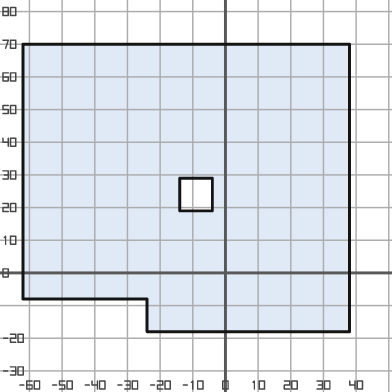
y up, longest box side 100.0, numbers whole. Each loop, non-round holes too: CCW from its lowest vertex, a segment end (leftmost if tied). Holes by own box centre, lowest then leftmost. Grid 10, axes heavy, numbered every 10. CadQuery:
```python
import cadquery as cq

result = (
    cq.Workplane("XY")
    .moveTo(-24.0, -18.0)
    .lineTo(38.0, -18.0)
    .lineTo(38.0, 70.0)
    .lineTo(-62.0, 70.0)
    .lineTo(-62.0, -8.0)
    .lineTo(-24.0, -8.0)
    .close()
    .moveTo(-14.0, 19.0)
    .lineTo(-4.0, 19.0)
    .lineTo(-4.0, 29.0)
    .lineTo(-14.0, 29.0)
    .close()
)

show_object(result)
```